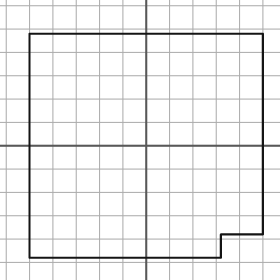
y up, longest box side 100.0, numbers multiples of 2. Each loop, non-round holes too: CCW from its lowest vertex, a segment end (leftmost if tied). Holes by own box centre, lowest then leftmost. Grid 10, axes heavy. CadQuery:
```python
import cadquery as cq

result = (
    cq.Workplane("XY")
    .moveTo(-50.0, -48.0)
    .lineTo(32.0, -48.0)
    .lineTo(32.0, -38.0)
    .lineTo(50.0, -38.0)
    .lineTo(50.0, 48.0)
    .lineTo(-50.0, 48.0)
    .close()
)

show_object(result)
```